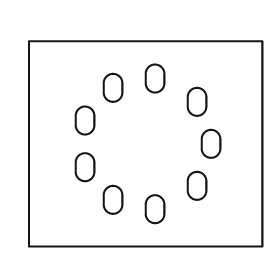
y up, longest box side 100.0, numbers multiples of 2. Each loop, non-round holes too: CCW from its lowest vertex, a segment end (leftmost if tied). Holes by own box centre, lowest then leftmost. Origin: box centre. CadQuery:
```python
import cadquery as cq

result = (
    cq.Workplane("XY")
    .moveTo(-50.0, -44.0)
    .lineTo(50.0, -44.0)
    .lineTo(50.0, 44.0)
    .lineTo(-50.0, 44.0)
    .close()
    .moveTo(0.0, -30.0)
    .threePointArc((4.0, -34.0), (8.0, -30.0))
    .lineTo(8.0, -26.0)
    .threePointArc((4.0, -22.0), (0.0, -26.0))
    .close()
    .moveTo(-18.0, -26.0)
    .threePointArc((-14.0, -30.0), (-10.0, -26.0))
    .lineTo(-10.0, -22.0)
    .threePointArc((-14.0, -18.0), (-18.0, -22.0))
    .close()
    .moveTo(18.0, -20.0)
    .threePointArc((22.0, -24.0), (26.0, -20.0))
    .lineTo(26.0, -16.0)
    .threePointArc((22.0, -12.0), (18.0, -16.0))
    .close()
    .moveTo(-30.0, -12.0)
    .threePointArc((-26.0, -16.0), (-22.0, -12.0))
    .lineTo(-22.0, -8.0)
    .threePointArc((-26.0, -4.0), (-30.0, -8.0))
    .close()
    .moveTo(24.0, -2.0)
    .threePointArc((28.0, -6.0), (32.0, -2.0))
    .lineTo(32.0, 2.0)
    .threePointArc((28.0, 6.0), (24.0, 2.0))
    .close()
    .moveTo(-30.0, 8.0)
    .threePointArc((-26.0, 4.0), (-22.0, 8.0))
    .lineTo(-22.0, 12.0)
    .threePointArc((-26.0, 16.0), (-30.0, 12.0))
    .close()
    .moveTo(18.0, 16.0)
    .threePointArc((22.0, 12.0), (26.0, 16.0))
    .lineTo(26.0, 20.0)
    .threePointArc((22.0, 24.0), (18.0, 20.0))
    .close()
    .moveTo(-18.0, 22.0)
    .threePointArc((-14.0, 18.0), (-10.0, 22.0))
    .lineTo(-10.0, 26.0)
    .threePointArc((-14.0, 30.0), (-18.0, 26.0))
    .close()
    .moveTo(0.0, 26.0)
    .threePointArc((4.0, 22.0), (8.0, 26.0))
    .lineTo(8.0, 30.0)
    .threePointArc((4.0, 34.0), (0.0, 30.0))
    .close()
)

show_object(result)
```